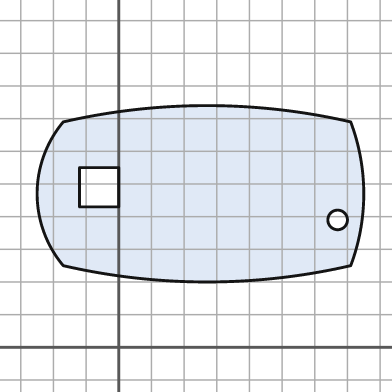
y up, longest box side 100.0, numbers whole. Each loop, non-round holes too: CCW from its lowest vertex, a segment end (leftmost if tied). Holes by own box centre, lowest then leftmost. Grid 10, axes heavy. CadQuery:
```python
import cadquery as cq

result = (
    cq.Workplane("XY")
    .moveTo(-17.0, 25.0)
    .threePointArc((27.0, 20.0), (71.0, 25.0))
    .threePointArc((75.0, 47.0), (71.0, 69.0))
    .threePointArc((27.0, 74.0), (-17.0, 69.0))
    .threePointArc((-25.0, 47.0), (-17.0, 25.0))
    .close()
    .moveTo(67.0, 39.0)
    .circle(3.0)
    .moveTo(-12.0, 43.0)
    .lineTo(0.0, 43.0)
    .lineTo(0.0, 55.0)
    .lineTo(-12.0, 55.0)
    .close()
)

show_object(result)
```